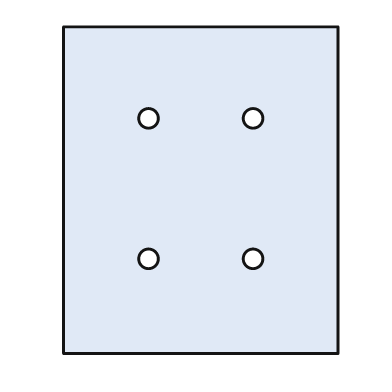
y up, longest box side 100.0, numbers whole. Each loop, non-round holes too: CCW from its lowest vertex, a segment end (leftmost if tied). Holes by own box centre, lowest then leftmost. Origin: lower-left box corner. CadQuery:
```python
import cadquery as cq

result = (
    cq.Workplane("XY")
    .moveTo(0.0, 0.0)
    .lineTo(84.0, 0.0)
    .lineTo(84.0, 100.0)
    .lineTo(0.0, 100.0)
    .close()
    .moveTo(26.0, 29.0)
    .circle(3.0)
    .moveTo(58.0, 29.0)
    .circle(3.0)
    .moveTo(26.0, 72.0)
    .circle(3.0)
    .moveTo(58.0, 72.0)
    .circle(3.0)
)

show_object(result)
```